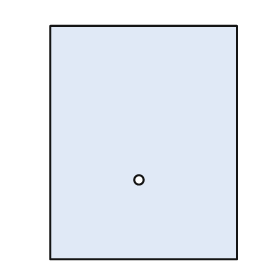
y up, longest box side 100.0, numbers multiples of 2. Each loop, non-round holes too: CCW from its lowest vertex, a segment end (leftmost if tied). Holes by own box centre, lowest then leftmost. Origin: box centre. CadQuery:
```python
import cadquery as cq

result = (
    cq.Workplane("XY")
    .moveTo(-40.0, -50.0)
    .lineTo(40.0, -50.0)
    .lineTo(40.0, 50.0)
    .lineTo(-40.0, 50.0)
    .close()
    .moveTo(-2.0, -16.0)
    .circle(2.0)
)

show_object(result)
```